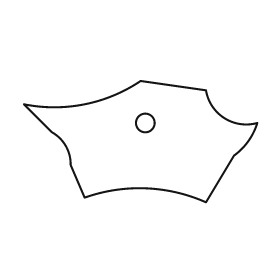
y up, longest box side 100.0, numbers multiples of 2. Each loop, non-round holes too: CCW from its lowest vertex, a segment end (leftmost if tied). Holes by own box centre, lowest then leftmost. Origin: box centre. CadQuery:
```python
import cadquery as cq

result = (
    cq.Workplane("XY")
    .moveTo(28.0, -26.0)
    .lineTo(40.0, -6.0)
    .threePointArc((46.0, 0.0), (50.0, 8.0))
    .threePointArc((36.0, 10.0), (28.0, 22.0))
    .lineTo(0.0, 26.0)
    .threePointArc((-24.0, 16.0), (-50.0, 16.0))
    .lineTo(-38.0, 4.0)
    .threePointArc((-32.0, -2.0), (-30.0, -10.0))
    .lineTo(-24.0, -24.0)
    .threePointArc((2.0, -20.0), (28.0, -26.0))
    .close()
    .moveTo(2.0, 8.0)
    .circle(4.0)
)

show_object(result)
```